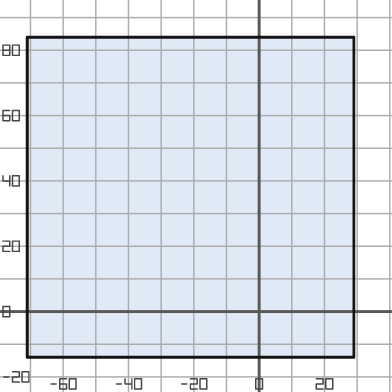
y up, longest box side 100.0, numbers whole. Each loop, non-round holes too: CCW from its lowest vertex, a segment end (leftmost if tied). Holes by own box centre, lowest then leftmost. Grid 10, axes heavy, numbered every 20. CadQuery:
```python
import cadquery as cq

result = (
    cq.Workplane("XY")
    .moveTo(-71.0, -14.0)
    .lineTo(29.0, -14.0)
    .lineTo(29.0, 84.0)
    .lineTo(-71.0, 84.0)
    .close()
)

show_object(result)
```